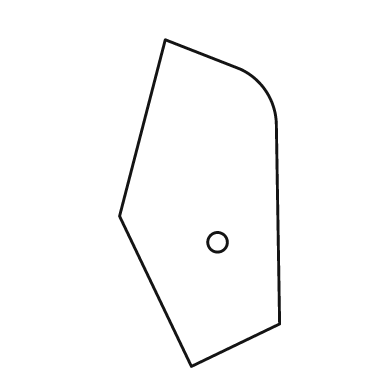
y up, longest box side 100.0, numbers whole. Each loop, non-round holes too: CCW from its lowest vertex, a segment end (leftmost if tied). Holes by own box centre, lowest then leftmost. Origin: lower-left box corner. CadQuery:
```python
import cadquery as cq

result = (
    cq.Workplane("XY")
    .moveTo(22.0, 0.0)
    .lineTo(49.0, 13.0)
    .lineTo(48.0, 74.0)
    .threePointArc((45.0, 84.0), (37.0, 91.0))
    .lineTo(14.0, 100.0)
    .lineTo(0.0, 46.0)
    .close()
    .moveTo(30.0, 38.0)
    .circle(3.0)
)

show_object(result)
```